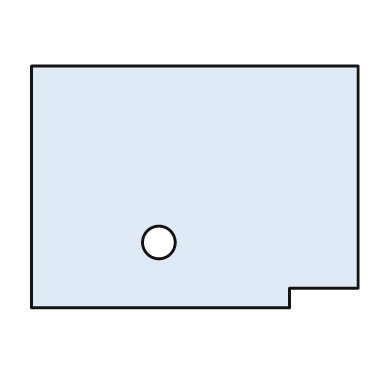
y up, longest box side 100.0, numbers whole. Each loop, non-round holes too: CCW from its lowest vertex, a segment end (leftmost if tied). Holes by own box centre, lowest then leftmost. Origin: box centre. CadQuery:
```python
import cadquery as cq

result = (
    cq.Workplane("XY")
    .moveTo(-50.0, -37.0)
    .lineTo(29.0, -37.0)
    .lineTo(29.0, -31.0)
    .lineTo(50.0, -31.0)
    .lineTo(50.0, 37.0)
    .lineTo(-50.0, 37.0)
    .close()
    .moveTo(-11.0, -17.0)
    .circle(5.0)
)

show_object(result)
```